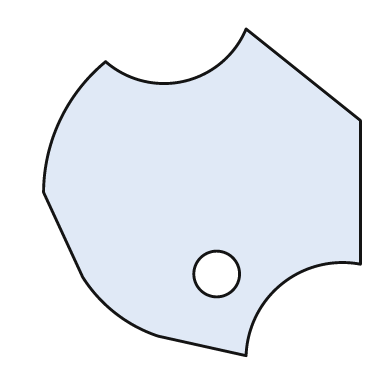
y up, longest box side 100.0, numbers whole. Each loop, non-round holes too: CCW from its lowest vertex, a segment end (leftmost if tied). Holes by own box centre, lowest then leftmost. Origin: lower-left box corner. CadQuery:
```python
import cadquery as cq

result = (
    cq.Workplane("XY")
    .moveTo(62.0, 0.0)
    .threePointArc((73.0, 22.0), (97.0, 28.0))
    .lineTo(97.0, 72.0)
    .lineTo(62.0, 100.0)
    .threePointArc((43.0, 84.0), (19.0, 90.0))
    .threePointArc((5.0, 72.0), (0.0, 50.0))
    .lineTo(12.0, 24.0)
    .threePointArc((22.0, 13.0), (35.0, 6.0))
    .close()
    .moveTo(53.0, 25.0)
    .circle(7.0)
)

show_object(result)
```